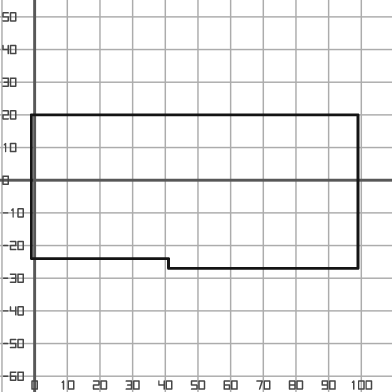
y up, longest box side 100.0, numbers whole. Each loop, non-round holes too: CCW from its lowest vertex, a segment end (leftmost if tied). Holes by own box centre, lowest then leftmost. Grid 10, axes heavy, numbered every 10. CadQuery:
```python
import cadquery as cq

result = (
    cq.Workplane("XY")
    .moveTo(41.0, -27.0)
    .lineTo(99.0, -27.0)
    .lineTo(99.0, 20.0)
    .lineTo(-1.0, 20.0)
    .lineTo(-1.0, -24.0)
    .lineTo(41.0, -24.0)
    .close()
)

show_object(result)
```